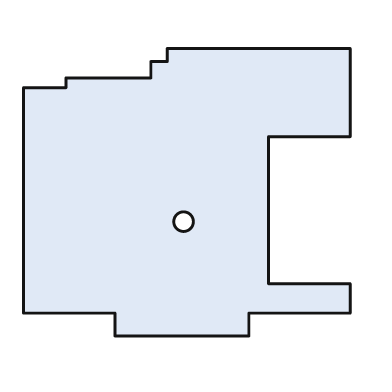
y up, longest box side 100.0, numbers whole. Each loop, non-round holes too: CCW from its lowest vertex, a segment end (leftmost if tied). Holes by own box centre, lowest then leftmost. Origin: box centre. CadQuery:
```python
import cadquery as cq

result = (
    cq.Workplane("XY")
    .moveTo(-22.0, -44.0)
    .lineTo(19.0, -44.0)
    .lineTo(19.0, -37.0)
    .lineTo(50.0, -37.0)
    .lineTo(50.0, -28.0)
    .lineTo(25.0, -28.0)
    .lineTo(25.0, 17.0)
    .lineTo(50.0, 17.0)
    .lineTo(50.0, 44.0)
    .lineTo(-6.0, 44.0)
    .lineTo(-6.0, 40.0)
    .lineTo(-11.0, 40.0)
    .lineTo(-11.0, 35.0)
    .lineTo(-37.0, 35.0)
    .lineTo(-37.0, 32.0)
    .lineTo(-50.0, 32.0)
    .lineTo(-50.0, -37.0)
    .lineTo(-22.0, -37.0)
    .close()
    .moveTo(-1.0, -9.0)
    .circle(3.0)
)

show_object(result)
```